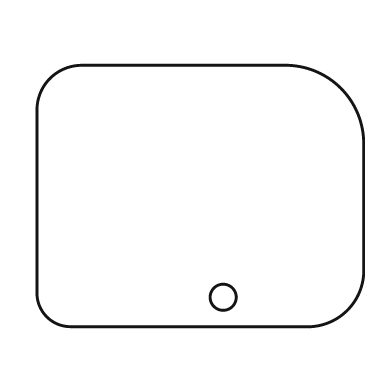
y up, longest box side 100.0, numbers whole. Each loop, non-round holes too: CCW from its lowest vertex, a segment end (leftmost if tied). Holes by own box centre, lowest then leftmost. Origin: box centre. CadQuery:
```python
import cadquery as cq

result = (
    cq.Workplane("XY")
    .moveTo(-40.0, -40.0)
    .lineTo(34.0, -40.0)
    .threePointArc((45.0, -35.0), (50.0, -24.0))
    .lineTo(50.0, 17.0)
    .threePointArc((43.0, 33.0), (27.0, 40.0))
    .lineTo(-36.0, 40.0)
    .threePointArc((-46.0, 36.0), (-50.0, 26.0))
    .lineTo(-50.0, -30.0)
    .threePointArc((-47.0, -37.0), (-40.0, -40.0))
    .close()
    .moveTo(7.0, -31.0)
    .circle(4.0)
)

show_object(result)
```